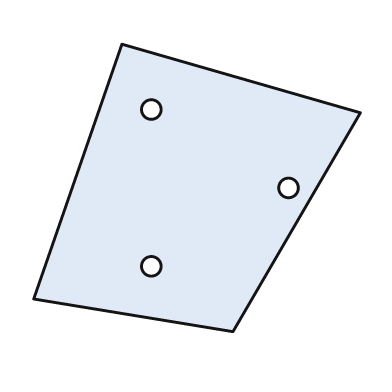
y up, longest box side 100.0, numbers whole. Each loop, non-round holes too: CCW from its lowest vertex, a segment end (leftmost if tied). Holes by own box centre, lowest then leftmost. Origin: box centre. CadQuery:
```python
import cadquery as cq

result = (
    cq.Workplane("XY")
    .moveTo(11.0, -44.0)
    .lineTo(50.0, 23.0)
    .lineTo(-23.0, 44.0)
    .lineTo(-50.0, -34.0)
    .close()
    .moveTo(-14.0, -24.0)
    .circle(3.0)
    .moveTo(28.0, 0.0)
    .circle(3.0)
    .moveTo(-14.0, 24.0)
    .circle(3.0)
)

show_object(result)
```